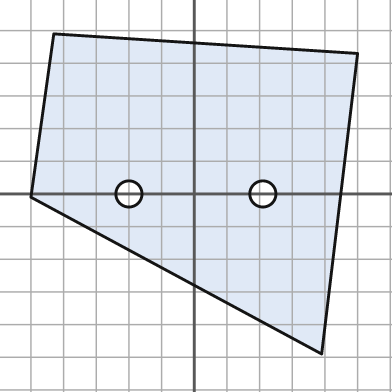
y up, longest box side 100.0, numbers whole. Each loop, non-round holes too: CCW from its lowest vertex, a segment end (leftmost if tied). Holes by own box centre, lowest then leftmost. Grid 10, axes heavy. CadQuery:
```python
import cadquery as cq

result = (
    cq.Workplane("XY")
    .moveTo(39.0, -49.0)
    .lineTo(50.0, 43.0)
    .lineTo(-43.0, 49.0)
    .lineTo(-50.0, -1.0)
    .close()
    .moveTo(-20.0, 0.0)
    .circle(4.0)
    .moveTo(21.0, 0.0)
    .circle(4.0)
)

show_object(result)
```